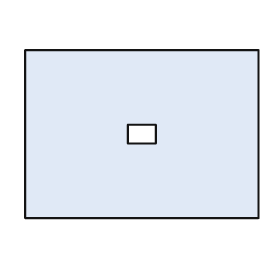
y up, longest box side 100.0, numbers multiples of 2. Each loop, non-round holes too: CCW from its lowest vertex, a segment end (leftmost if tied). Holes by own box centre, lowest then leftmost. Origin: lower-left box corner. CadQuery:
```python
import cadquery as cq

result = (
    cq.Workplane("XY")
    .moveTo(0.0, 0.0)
    .lineTo(100.0, 0.0)
    .lineTo(100.0, 72.0)
    .lineTo(0.0, 72.0)
    .close()
    .moveTo(44.0, 32.0)
    .lineTo(56.0, 32.0)
    .lineTo(56.0, 40.0)
    .lineTo(44.0, 40.0)
    .close()
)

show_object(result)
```